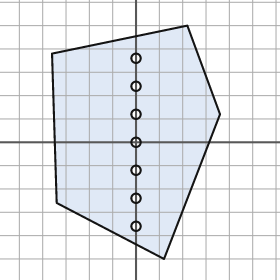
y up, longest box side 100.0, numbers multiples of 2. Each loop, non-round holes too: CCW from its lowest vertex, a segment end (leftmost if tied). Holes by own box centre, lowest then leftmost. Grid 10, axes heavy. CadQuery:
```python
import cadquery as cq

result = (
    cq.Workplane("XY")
    .moveTo(12.0, -50.0)
    .lineTo(36.0, 12.0)
    .lineTo(22.0, 50.0)
    .lineTo(-36.0, 38.0)
    .lineTo(-34.0, -26.0)
    .close()
    .moveTo(0.0, -36.0)
    .circle(2.0)
    .moveTo(0.0, -24.0)
    .circle(2.0)
    .moveTo(0.0, -12.0)
    .circle(2.0)
    .moveTo(0.0, 0.0)
    .circle(2.0)
    .moveTo(0.0, 12.0)
    .circle(2.0)
    .moveTo(0.0, 24.0)
    .circle(2.0)
    .moveTo(0.0, 36.0)
    .circle(2.0)
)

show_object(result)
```